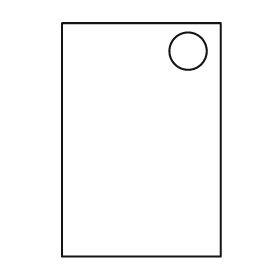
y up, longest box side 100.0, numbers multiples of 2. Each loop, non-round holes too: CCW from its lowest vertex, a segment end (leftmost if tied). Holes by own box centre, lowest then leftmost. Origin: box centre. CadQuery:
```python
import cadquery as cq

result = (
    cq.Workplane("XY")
    .moveTo(-34.0, -50.0)
    .lineTo(34.0, -50.0)
    .lineTo(34.0, 50.0)
    .lineTo(-34.0, 50.0)
    .close()
    .moveTo(20.0, 38.0)
    .circle(8.0)
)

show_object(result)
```